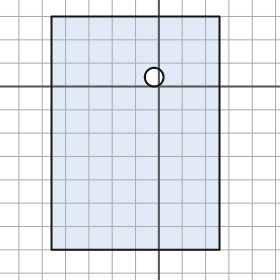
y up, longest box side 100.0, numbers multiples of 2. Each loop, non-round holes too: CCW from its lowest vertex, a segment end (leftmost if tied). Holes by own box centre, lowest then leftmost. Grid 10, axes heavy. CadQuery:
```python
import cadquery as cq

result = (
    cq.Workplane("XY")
    .moveTo(-46.0, -70.0)
    .lineTo(26.0, -70.0)
    .lineTo(26.0, 30.0)
    .lineTo(-46.0, 30.0)
    .close()
    .moveTo(-2.0, 4.0)
    .circle(4.0)
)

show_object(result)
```